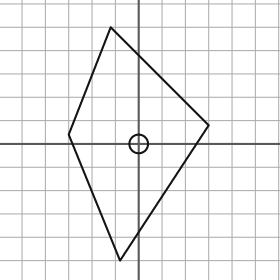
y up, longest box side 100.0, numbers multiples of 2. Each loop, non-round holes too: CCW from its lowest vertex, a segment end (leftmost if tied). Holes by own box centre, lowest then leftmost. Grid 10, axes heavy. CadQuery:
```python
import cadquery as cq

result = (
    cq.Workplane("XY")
    .moveTo(-8.0, -50.0)
    .lineTo(30.0, 8.0)
    .lineTo(-12.0, 50.0)
    .lineTo(-30.0, 4.0)
    .close()
    .moveTo(0.0, 0.0)
    .circle(4.0)
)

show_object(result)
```